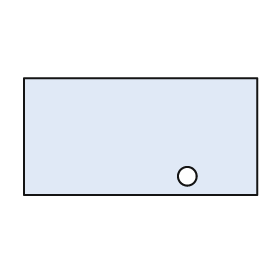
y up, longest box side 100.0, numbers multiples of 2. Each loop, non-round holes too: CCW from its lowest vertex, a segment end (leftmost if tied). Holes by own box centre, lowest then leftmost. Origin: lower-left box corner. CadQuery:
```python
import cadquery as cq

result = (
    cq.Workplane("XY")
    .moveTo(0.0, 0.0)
    .lineTo(100.0, 0.0)
    .lineTo(100.0, 50.0)
    .lineTo(0.0, 50.0)
    .close()
    .moveTo(70.0, 8.0)
    .circle(4.0)
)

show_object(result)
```